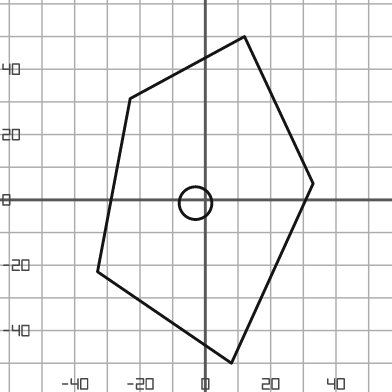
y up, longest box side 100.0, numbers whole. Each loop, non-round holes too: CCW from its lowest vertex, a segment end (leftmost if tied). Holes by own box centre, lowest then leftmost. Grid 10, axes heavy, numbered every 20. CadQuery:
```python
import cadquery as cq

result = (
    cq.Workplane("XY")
    .moveTo(8.0, -50.0)
    .lineTo(33.0, 5.0)
    .lineTo(12.0, 50.0)
    .lineTo(-23.0, 31.0)
    .lineTo(-33.0, -22.0)
    .close()
    .moveTo(-3.0, -1.0)
    .circle(5.0)
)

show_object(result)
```